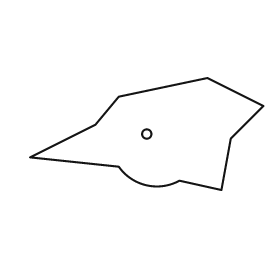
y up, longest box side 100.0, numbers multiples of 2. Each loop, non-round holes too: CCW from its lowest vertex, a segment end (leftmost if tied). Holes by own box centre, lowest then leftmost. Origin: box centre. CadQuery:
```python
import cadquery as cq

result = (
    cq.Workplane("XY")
    .moveTo(32.0, -24.0)
    .lineTo(36.0, -2.0)
    .lineTo(50.0, 12.0)
    .lineTo(26.0, 24.0)
    .lineTo(-12.0, 16.0)
    .lineTo(-22.0, 4.0)
    .lineTo(-50.0, -10.0)
    .lineTo(-12.0, -14.0)
    .threePointArc((0.0, -22.0), (14.0, -20.0))
    .close()
    .moveTo(0.0, 0.0)
    .circle(2.0)
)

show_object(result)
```